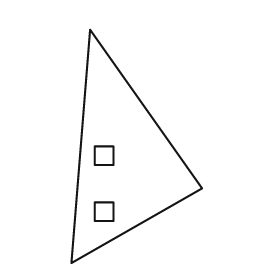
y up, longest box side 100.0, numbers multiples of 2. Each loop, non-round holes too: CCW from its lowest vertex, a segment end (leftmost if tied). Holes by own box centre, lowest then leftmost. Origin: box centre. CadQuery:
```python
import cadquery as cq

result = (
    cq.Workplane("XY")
    .moveTo(-28.0, -50.0)
    .lineTo(28.0, -18.0)
    .lineTo(-20.0, 50.0)
    .close()
    .moveTo(-18.0, -32.0)
    .lineTo(-10.0, -32.0)
    .lineTo(-10.0, -24.0)
    .lineTo(-18.0, -24.0)
    .close()
    .moveTo(-18.0, -8.0)
    .lineTo(-10.0, -8.0)
    .lineTo(-10.0, 0.0)
    .lineTo(-18.0, 0.0)
    .close()
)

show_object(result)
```